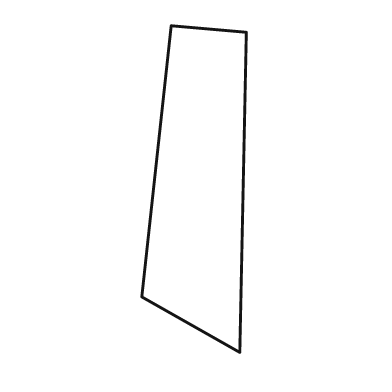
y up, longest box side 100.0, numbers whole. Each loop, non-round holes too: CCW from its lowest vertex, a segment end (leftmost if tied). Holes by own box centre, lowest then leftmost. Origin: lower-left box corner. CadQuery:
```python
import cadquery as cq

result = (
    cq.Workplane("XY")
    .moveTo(30.0, 0.0)
    .lineTo(32.0, 98.0)
    .lineTo(9.0, 100.0)
    .lineTo(0.0, 17.0)
    .close()
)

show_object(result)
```